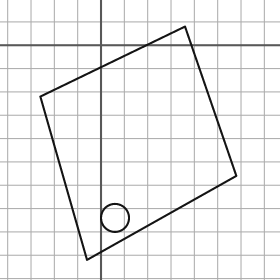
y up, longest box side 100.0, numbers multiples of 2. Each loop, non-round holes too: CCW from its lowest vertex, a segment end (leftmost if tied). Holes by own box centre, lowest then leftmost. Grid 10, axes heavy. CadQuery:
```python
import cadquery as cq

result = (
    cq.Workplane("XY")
    .moveTo(-6.0, -92.0)
    .lineTo(58.0, -56.0)
    .lineTo(36.0, 8.0)
    .lineTo(-26.0, -22.0)
    .close()
    .moveTo(6.0, -74.0)
    .circle(6.0)
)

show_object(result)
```